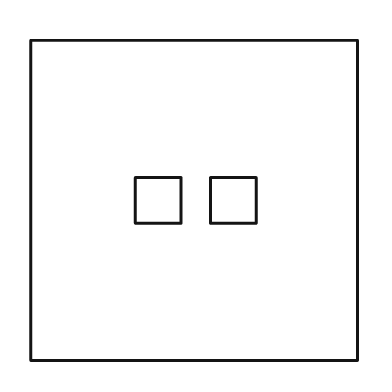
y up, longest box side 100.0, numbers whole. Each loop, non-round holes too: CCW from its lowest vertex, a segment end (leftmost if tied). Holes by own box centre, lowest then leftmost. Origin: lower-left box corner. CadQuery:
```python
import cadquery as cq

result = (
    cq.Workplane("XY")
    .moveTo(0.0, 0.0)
    .lineTo(100.0, 0.0)
    .lineTo(100.0, 98.0)
    .lineTo(0.0, 98.0)
    .close()
    .moveTo(32.0, 42.0)
    .lineTo(46.0, 42.0)
    .lineTo(46.0, 56.0)
    .lineTo(32.0, 56.0)
    .close()
    .moveTo(55.0, 42.0)
    .lineTo(69.0, 42.0)
    .lineTo(69.0, 56.0)
    .lineTo(55.0, 56.0)
    .close()
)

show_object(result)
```